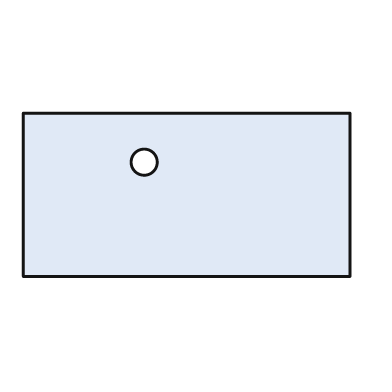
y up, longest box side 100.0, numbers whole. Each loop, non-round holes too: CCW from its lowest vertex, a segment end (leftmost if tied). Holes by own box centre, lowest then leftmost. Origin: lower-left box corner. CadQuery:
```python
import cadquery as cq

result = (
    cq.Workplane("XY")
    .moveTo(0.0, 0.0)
    .lineTo(100.0, 0.0)
    .lineTo(100.0, 50.0)
    .lineTo(0.0, 50.0)
    .close()
    .moveTo(37.0, 35.0)
    .circle(4.0)
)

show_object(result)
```